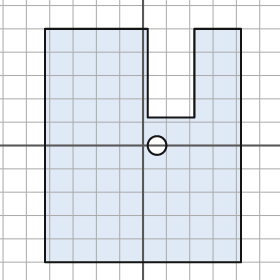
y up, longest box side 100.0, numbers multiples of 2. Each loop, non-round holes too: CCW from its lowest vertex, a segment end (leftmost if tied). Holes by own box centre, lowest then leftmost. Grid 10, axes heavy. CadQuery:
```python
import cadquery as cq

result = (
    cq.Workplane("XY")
    .moveTo(-42.0, -50.0)
    .lineTo(42.0, -50.0)
    .lineTo(42.0, 50.0)
    .lineTo(22.0, 50.0)
    .lineTo(22.0, 12.0)
    .lineTo(2.0, 12.0)
    .lineTo(2.0, 50.0)
    .lineTo(-42.0, 50.0)
    .close()
    .moveTo(6.0, 0.0)
    .circle(4.0)
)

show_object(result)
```